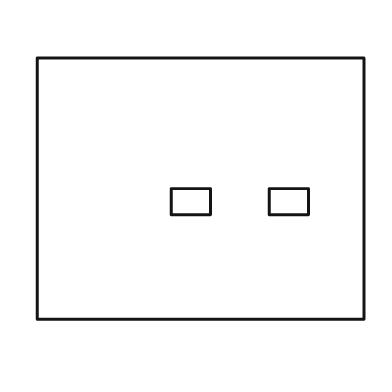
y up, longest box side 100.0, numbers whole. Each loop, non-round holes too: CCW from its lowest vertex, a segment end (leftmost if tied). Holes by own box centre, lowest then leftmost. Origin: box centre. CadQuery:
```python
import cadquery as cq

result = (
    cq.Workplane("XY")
    .moveTo(-50.0, -40.0)
    .lineTo(50.0, -40.0)
    .lineTo(50.0, 40.0)
    .lineTo(-50.0, 40.0)
    .close()
    .moveTo(-9.0, -8.0)
    .lineTo(3.0, -8.0)
    .lineTo(3.0, 0.0)
    .lineTo(-9.0, 0.0)
    .close()
    .moveTo(21.0, -8.0)
    .lineTo(33.0, -8.0)
    .lineTo(33.0, 0.0)
    .lineTo(21.0, 0.0)
    .close()
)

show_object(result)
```